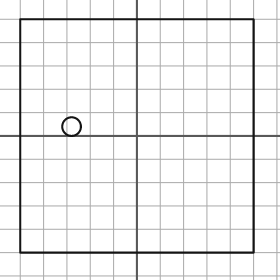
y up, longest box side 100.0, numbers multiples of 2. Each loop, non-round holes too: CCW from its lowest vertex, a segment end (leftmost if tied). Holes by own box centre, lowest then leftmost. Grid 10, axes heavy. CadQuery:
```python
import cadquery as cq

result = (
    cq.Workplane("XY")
    .moveTo(-50.0, -50.0)
    .lineTo(50.0, -50.0)
    .lineTo(50.0, 50.0)
    .lineTo(-50.0, 50.0)
    .close()
    .moveTo(-28.0, 4.0)
    .circle(4.0)
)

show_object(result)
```